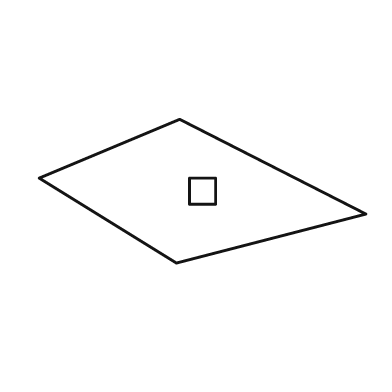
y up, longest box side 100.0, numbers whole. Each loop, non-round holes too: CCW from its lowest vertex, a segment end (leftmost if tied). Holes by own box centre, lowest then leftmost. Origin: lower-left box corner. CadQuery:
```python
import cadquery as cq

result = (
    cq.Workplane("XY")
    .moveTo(42.0, 0.0)
    .lineTo(100.0, 15.0)
    .lineTo(43.0, 44.0)
    .lineTo(0.0, 26.0)
    .close()
    .moveTo(46.0, 18.0)
    .lineTo(54.0, 18.0)
    .lineTo(54.0, 26.0)
    .lineTo(46.0, 26.0)
    .close()
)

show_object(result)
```